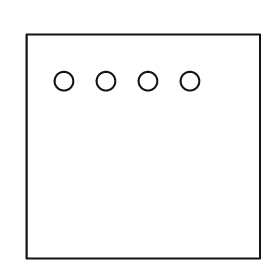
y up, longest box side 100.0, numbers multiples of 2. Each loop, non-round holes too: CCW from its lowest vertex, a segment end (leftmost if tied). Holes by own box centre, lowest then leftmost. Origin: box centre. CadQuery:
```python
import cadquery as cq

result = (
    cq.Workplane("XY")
    .moveTo(-50.0, -48.0)
    .lineTo(50.0, -48.0)
    .lineTo(50.0, 48.0)
    .lineTo(-50.0, 48.0)
    .close()
    .moveTo(-34.0, 28.0)
    .circle(4.0)
    .moveTo(-16.0, 28.0)
    .circle(4.0)
    .moveTo(2.0, 28.0)
    .circle(4.0)
    .moveTo(20.0, 28.0)
    .circle(4.0)
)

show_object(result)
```